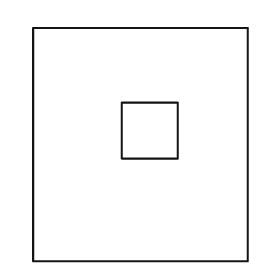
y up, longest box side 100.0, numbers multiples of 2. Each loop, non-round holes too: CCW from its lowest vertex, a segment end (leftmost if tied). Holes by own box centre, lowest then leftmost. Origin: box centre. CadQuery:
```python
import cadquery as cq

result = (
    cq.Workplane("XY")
    .moveTo(-46.0, -50.0)
    .lineTo(46.0, -50.0)
    .lineTo(46.0, 50.0)
    .lineTo(-46.0, 50.0)
    .close()
    .moveTo(-8.0, -6.0)
    .lineTo(16.0, -6.0)
    .lineTo(16.0, 18.0)
    .lineTo(-8.0, 18.0)
    .close()
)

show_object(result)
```